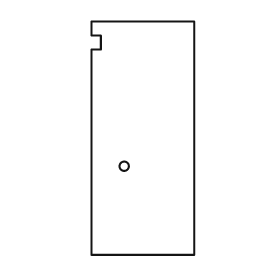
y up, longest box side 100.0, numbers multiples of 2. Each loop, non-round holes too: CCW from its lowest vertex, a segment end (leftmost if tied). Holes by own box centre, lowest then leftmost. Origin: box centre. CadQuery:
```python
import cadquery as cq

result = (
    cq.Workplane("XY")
    .moveTo(-22.0, -50.0)
    .lineTo(22.0, -50.0)
    .lineTo(22.0, 50.0)
    .lineTo(-22.0, 50.0)
    .lineTo(-22.0, 44.0)
    .lineTo(-18.0, 44.0)
    .lineTo(-18.0, 38.0)
    .lineTo(-22.0, 38.0)
    .close()
    .moveTo(-8.0, -12.0)
    .circle(2.0)
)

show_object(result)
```